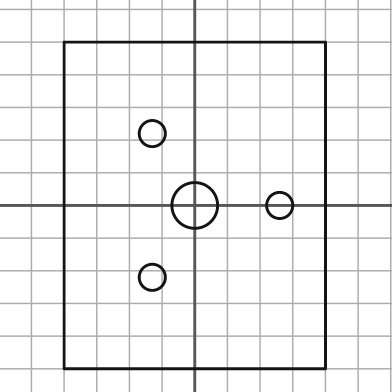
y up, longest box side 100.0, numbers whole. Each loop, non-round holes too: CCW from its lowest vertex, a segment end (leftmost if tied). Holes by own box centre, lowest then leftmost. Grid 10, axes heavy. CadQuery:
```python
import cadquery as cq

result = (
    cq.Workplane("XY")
    .moveTo(-40.0, -50.0)
    .lineTo(40.0, -50.0)
    .lineTo(40.0, 50.0)
    .lineTo(-40.0, 50.0)
    .close()
    .moveTo(-13.0, -22.0)
    .circle(4.0)
    .moveTo(0.0, 0.0)
    .circle(7.0)
    .moveTo(26.0, 0.0)
    .circle(4.0)
    .moveTo(-13.0, 22.0)
    .circle(4.0)
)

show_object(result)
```